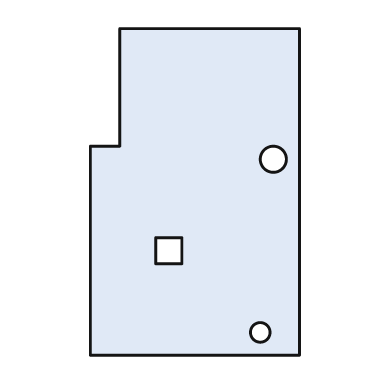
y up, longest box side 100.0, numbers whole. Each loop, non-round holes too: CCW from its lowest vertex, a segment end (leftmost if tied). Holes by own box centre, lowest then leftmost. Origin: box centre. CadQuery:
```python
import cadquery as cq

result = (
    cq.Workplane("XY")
    .moveTo(-32.0, -50.0)
    .lineTo(32.0, -50.0)
    .lineTo(32.0, 50.0)
    .lineTo(-23.0, 50.0)
    .lineTo(-23.0, 14.0)
    .lineTo(-32.0, 14.0)
    .close()
    .moveTo(20.0, -43.0)
    .circle(3.0)
    .moveTo(-12.0, -22.0)
    .lineTo(-4.0, -22.0)
    .lineTo(-4.0, -14.0)
    .lineTo(-12.0, -14.0)
    .close()
    .moveTo(24.0, 10.0)
    .circle(4.0)
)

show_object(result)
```